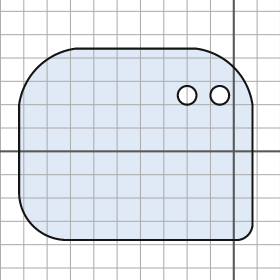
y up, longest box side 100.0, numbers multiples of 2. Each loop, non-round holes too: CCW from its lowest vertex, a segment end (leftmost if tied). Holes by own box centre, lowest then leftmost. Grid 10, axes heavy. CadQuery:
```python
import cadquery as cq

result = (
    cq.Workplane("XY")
    .moveTo(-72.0, -38.0)
    .lineTo(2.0, -38.0)
    .threePointArc((6.0, -36.0), (8.0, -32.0))
    .lineTo(8.0, 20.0)
    .threePointArc((0.0, 36.0), (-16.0, 44.0))
    .lineTo(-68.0, 44.0)
    .threePointArc((-84.0, 36.0), (-92.0, 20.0))
    .lineTo(-92.0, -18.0)
    .threePointArc((-86.0, -32.0), (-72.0, -38.0))
    .close()
    .moveTo(-20.0, 24.0)
    .circle(4.0)
    .moveTo(-6.0, 24.0)
    .circle(4.0)
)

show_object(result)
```